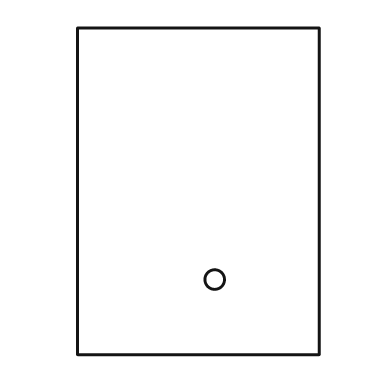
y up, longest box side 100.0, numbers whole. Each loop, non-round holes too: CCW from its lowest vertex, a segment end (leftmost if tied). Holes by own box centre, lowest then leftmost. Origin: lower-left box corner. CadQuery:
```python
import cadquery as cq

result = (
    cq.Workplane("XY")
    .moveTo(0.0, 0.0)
    .lineTo(74.0, 0.0)
    .lineTo(74.0, 100.0)
    .lineTo(0.0, 100.0)
    .close()
    .moveTo(42.0, 23.0)
    .circle(3.0)
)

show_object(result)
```